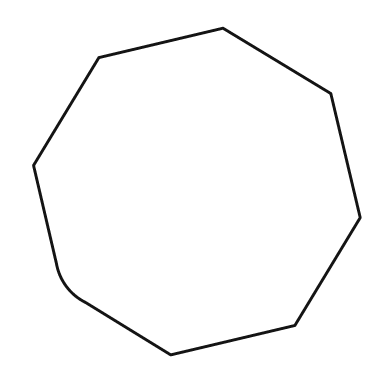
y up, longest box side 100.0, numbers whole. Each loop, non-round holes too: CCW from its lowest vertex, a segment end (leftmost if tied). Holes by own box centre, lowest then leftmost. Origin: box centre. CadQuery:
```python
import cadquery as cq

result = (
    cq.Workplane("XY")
    .moveTo(-8.0, -50.0)
    .lineTo(30.0, -41.0)
    .lineTo(50.0, -8.0)
    .lineTo(41.0, 30.0)
    .lineTo(8.0, 50.0)
    .lineTo(-30.0, 41.0)
    .lineTo(-50.0, 8.0)
    .lineTo(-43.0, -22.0)
    .threePointArc((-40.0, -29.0), (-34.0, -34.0))
    .close()
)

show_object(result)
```